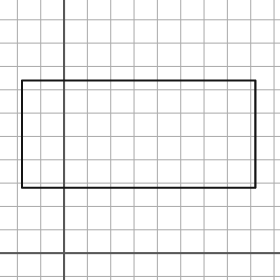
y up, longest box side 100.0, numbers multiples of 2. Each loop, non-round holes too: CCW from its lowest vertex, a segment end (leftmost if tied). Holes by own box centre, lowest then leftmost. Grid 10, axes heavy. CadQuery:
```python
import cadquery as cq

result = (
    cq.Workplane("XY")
    .moveTo(-18.0, 28.0)
    .lineTo(82.0, 28.0)
    .lineTo(82.0, 74.0)
    .lineTo(-18.0, 74.0)
    .close()
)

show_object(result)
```